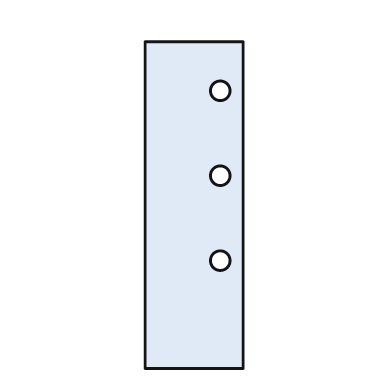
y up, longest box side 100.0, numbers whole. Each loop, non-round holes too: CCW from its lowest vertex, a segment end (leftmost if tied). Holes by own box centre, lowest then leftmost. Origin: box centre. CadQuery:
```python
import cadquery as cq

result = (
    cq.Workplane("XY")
    .moveTo(-15.0, -50.0)
    .lineTo(15.0, -50.0)
    .lineTo(15.0, 50.0)
    .lineTo(-15.0, 50.0)
    .close()
    .moveTo(8.0, -17.0)
    .circle(3.0)
    .moveTo(8.0, 9.0)
    .circle(3.0)
    .moveTo(8.0, 35.0)
    .circle(3.0)
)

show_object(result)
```